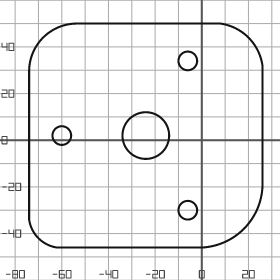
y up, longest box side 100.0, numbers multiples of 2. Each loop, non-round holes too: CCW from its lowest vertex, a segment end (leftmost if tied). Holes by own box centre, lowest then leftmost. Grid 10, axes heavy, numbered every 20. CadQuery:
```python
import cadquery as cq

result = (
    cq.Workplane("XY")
    .moveTo(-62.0, -46.0)
    .lineTo(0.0, -46.0)
    .threePointArc((18.0, -38.0), (26.0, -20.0))
    .lineTo(26.0, 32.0)
    .threePointArc((20.0, 44.0), (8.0, 50.0))
    .lineTo(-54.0, 50.0)
    .threePointArc((-68.0, 44.0), (-74.0, 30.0))
    .lineTo(-74.0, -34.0)
    .threePointArc((-70.0, -42.0), (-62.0, -46.0))
    .close()
    .moveTo(-6.0, -30.0)
    .circle(4.0)
    .moveTo(-60.0, 2.0)
    .circle(4.0)
    .moveTo(-24.0, 2.0)
    .circle(10.0)
    .moveTo(-6.0, 34.0)
    .circle(4.0)
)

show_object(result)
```